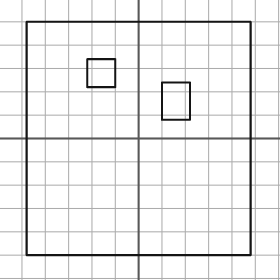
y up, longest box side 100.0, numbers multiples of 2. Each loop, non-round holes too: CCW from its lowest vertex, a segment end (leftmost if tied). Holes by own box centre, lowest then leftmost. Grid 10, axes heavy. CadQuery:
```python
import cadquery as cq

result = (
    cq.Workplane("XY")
    .moveTo(-48.0, -50.0)
    .lineTo(48.0, -50.0)
    .lineTo(48.0, 50.0)
    .lineTo(-48.0, 50.0)
    .close()
    .moveTo(10.0, 8.0)
    .lineTo(22.0, 8.0)
    .lineTo(22.0, 24.0)
    .lineTo(10.0, 24.0)
    .close()
    .moveTo(-22.0, 22.0)
    .lineTo(-10.0, 22.0)
    .lineTo(-10.0, 34.0)
    .lineTo(-22.0, 34.0)
    .close()
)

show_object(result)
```